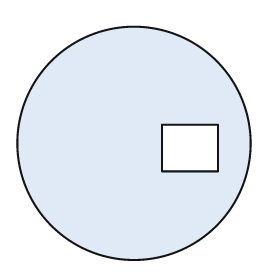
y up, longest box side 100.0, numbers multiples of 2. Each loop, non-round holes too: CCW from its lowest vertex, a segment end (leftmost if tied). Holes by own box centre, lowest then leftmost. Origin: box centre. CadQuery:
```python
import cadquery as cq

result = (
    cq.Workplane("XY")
    .moveTo(0.0, 0.0)
    .circle(50.0)
    .moveTo(12.0, -12.0)
    .lineTo(36.0, -12.0)
    .lineTo(36.0, 8.0)
    .lineTo(12.0, 8.0)
    .close()
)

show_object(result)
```